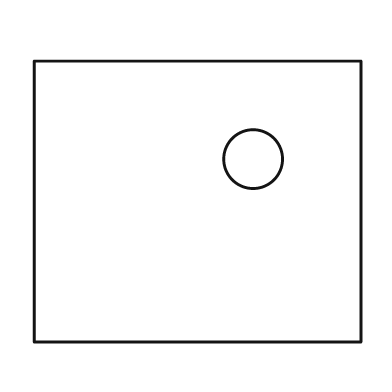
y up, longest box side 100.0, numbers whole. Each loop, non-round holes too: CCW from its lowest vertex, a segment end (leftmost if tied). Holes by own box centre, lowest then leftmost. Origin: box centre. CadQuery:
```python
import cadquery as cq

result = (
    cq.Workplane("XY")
    .moveTo(-50.0, -43.0)
    .lineTo(50.0, -43.0)
    .lineTo(50.0, 43.0)
    .lineTo(-50.0, 43.0)
    .close()
    .moveTo(17.0, 13.0)
    .circle(9.0)
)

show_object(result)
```